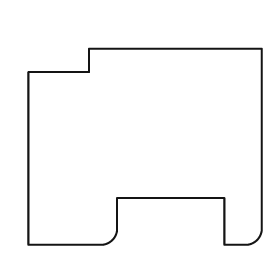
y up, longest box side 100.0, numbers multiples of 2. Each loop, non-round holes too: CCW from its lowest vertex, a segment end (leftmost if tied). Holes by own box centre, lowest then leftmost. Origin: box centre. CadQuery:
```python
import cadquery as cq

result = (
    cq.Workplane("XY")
    .moveTo(-50.0, -42.0)
    .lineTo(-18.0, -42.0)
    .threePointArc((-14.0, -40.0), (-12.0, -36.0))
    .lineTo(-12.0, -22.0)
    .lineTo(34.0, -22.0)
    .lineTo(34.0, -42.0)
    .lineTo(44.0, -42.0)
    .threePointArc((48.0, -40.0), (50.0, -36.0))
    .lineTo(50.0, 42.0)
    .lineTo(-24.0, 42.0)
    .lineTo(-24.0, 32.0)
    .lineTo(-50.0, 32.0)
    .close()
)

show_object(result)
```